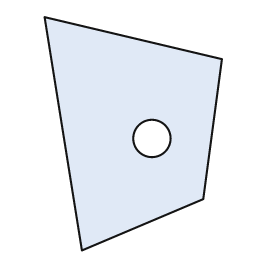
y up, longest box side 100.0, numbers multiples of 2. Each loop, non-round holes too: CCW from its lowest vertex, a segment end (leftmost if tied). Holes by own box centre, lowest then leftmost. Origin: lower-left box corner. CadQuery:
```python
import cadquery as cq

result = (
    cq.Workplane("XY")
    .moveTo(16.0, 0.0)
    .lineTo(68.0, 22.0)
    .lineTo(76.0, 82.0)
    .lineTo(0.0, 100.0)
    .close()
    .moveTo(46.0, 48.0)
    .circle(8.0)
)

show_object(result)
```